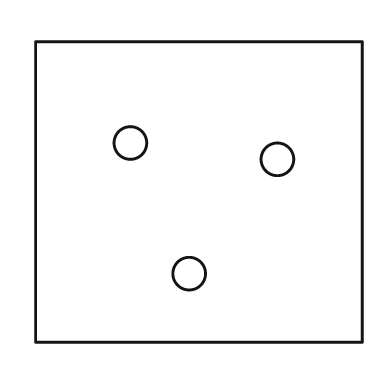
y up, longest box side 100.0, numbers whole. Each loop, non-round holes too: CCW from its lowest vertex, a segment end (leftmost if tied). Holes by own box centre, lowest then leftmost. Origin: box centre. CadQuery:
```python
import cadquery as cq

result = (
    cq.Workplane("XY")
    .moveTo(-50.0, -46.0)
    .lineTo(50.0, -46.0)
    .lineTo(50.0, 46.0)
    .lineTo(-50.0, 46.0)
    .close()
    .moveTo(-3.0, -25.0)
    .circle(5.0)
    .moveTo(24.0, 10.0)
    .circle(5.0)
    .moveTo(-21.0, 15.0)
    .circle(5.0)
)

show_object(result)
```